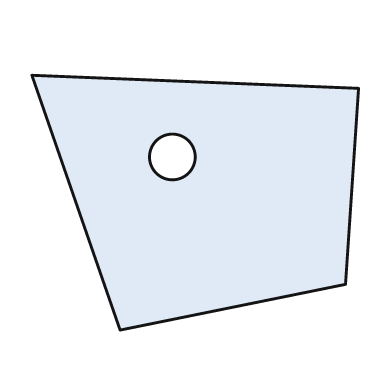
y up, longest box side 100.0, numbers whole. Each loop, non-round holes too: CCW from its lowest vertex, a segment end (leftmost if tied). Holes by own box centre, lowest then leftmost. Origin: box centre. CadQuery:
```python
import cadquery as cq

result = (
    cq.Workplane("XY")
    .moveTo(-23.0, -39.0)
    .lineTo(46.0, -25.0)
    .lineTo(50.0, 35.0)
    .lineTo(-50.0, 39.0)
    .close()
    .moveTo(-7.0, 14.0)
    .circle(7.0)
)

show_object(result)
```